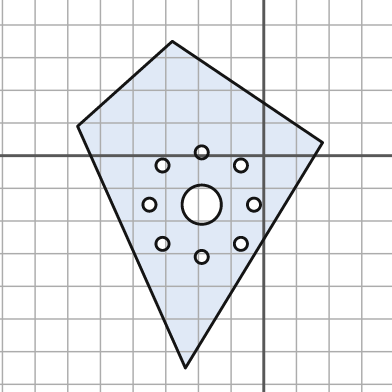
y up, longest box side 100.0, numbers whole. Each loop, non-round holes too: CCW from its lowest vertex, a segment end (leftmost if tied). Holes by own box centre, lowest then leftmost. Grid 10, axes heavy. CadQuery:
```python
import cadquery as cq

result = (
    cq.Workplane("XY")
    .moveTo(-24.0, -65.0)
    .lineTo(18.0, 4.0)
    .lineTo(-28.0, 35.0)
    .lineTo(-57.0, 9.0)
    .close()
    .moveTo(-19.0, -31.0)
    .circle(2.0)
    .moveTo(-31.0, -27.0)
    .circle(2.0)
    .moveTo(-7.0, -27.0)
    .circle(2.0)
    .moveTo(-35.0, -15.0)
    .circle(2.0)
    .moveTo(-19.0, -15.0)
    .circle(6.0)
    .moveTo(-3.0, -15.0)
    .circle(2.0)
    .moveTo(-31.0, -3.0)
    .circle(2.0)
    .moveTo(-7.0, -3.0)
    .circle(2.0)
    .moveTo(-19.0, 1.0)
    .circle(2.0)
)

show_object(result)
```